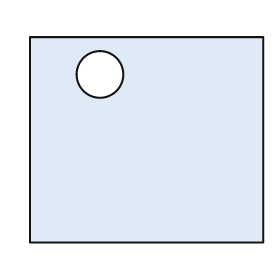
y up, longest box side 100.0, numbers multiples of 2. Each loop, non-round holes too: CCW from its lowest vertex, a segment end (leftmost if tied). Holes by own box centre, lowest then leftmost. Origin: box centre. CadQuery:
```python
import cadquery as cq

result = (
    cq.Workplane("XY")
    .moveTo(-50.0, -44.0)
    .lineTo(50.0, -44.0)
    .lineTo(50.0, 44.0)
    .lineTo(-50.0, 44.0)
    .close()
    .moveTo(-20.0, 28.0)
    .circle(10.0)
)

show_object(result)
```